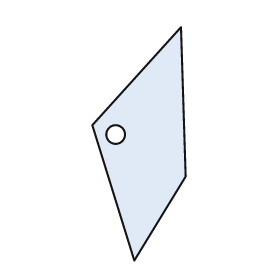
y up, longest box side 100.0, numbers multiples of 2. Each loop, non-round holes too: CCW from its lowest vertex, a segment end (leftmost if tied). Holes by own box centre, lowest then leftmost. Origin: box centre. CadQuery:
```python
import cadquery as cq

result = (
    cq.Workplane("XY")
    .moveTo(-2.0, -50.0)
    .lineTo(20.0, -14.0)
    .lineTo(18.0, 50.0)
    .lineTo(-20.0, 8.0)
    .close()
    .moveTo(-10.0, 4.0)
    .circle(4.0)
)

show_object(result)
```